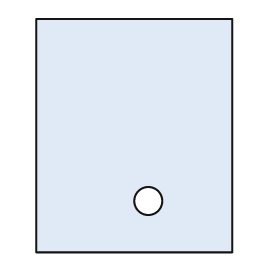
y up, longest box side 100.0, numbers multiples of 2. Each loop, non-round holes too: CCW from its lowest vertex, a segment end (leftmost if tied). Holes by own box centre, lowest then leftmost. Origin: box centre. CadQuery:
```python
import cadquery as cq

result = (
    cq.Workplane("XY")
    .moveTo(-42.0, -50.0)
    .lineTo(42.0, -50.0)
    .lineTo(42.0, 50.0)
    .lineTo(-42.0, 50.0)
    .close()
    .moveTo(6.0, -28.0)
    .circle(6.0)
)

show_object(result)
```